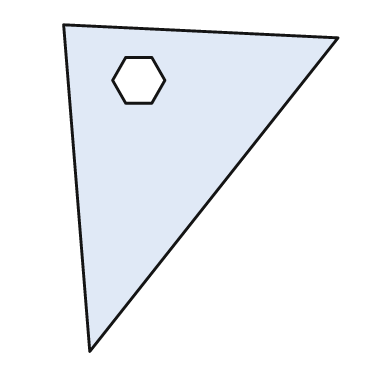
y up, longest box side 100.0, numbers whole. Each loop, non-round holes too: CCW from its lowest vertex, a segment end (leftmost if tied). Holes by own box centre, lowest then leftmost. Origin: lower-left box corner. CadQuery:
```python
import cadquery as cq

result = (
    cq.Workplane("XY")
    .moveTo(8.0, 0.0)
    .lineTo(84.0, 96.0)
    .lineTo(0.0, 100.0)
    .close()
    .moveTo(19.0, 76.0)
    .lineTo(27.0, 76.0)
    .lineTo(31.0, 83.0)
    .lineTo(27.0, 90.0)
    .lineTo(19.0, 90.0)
    .lineTo(15.0, 83.0)
    .close()
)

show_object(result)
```